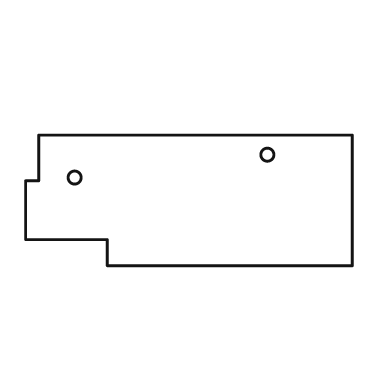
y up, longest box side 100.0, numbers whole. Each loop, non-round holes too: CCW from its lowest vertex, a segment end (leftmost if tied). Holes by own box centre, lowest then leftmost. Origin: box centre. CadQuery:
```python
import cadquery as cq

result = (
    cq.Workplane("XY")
    .moveTo(-25.0, -20.0)
    .lineTo(50.0, -20.0)
    .lineTo(50.0, 20.0)
    .lineTo(-46.0, 20.0)
    .lineTo(-46.0, 6.0)
    .lineTo(-50.0, 6.0)
    .lineTo(-50.0, -12.0)
    .lineTo(-25.0, -12.0)
    .close()
    .moveTo(-35.0, 7.0)
    .circle(2.0)
    .moveTo(24.0, 14.0)
    .circle(2.0)
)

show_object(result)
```